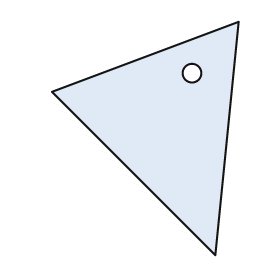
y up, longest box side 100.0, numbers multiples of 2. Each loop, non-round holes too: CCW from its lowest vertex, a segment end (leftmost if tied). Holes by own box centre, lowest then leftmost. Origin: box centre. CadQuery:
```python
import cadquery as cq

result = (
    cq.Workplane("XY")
    .moveTo(30.0, -50.0)
    .lineTo(40.0, 50.0)
    .lineTo(-40.0, 20.0)
    .close()
    .moveTo(20.0, 28.0)
    .circle(4.0)
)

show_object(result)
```